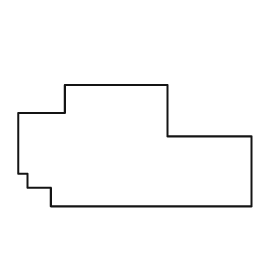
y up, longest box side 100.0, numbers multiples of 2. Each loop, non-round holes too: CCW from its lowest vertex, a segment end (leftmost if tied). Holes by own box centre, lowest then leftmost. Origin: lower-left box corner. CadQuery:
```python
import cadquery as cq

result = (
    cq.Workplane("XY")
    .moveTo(14.0, 0.0)
    .lineTo(100.0, 0.0)
    .lineTo(100.0, 30.0)
    .lineTo(64.0, 30.0)
    .lineTo(64.0, 52.0)
    .lineTo(20.0, 52.0)
    .lineTo(20.0, 40.0)
    .lineTo(0.0, 40.0)
    .lineTo(0.0, 14.0)
    .lineTo(4.0, 14.0)
    .lineTo(4.0, 8.0)
    .lineTo(14.0, 8.0)
    .close()
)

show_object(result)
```